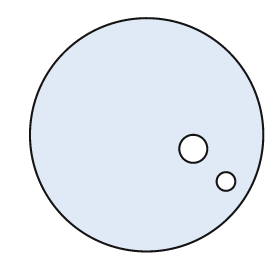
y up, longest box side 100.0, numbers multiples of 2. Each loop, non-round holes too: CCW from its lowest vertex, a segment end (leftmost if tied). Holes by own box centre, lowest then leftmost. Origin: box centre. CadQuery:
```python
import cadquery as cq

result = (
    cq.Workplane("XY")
    .moveTo(0.0, 0.0)
    .circle(50.0)
    .moveTo(34.0, -20.0)
    .circle(4.0)
    .moveTo(20.0, -6.0)
    .circle(6.0)
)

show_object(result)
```